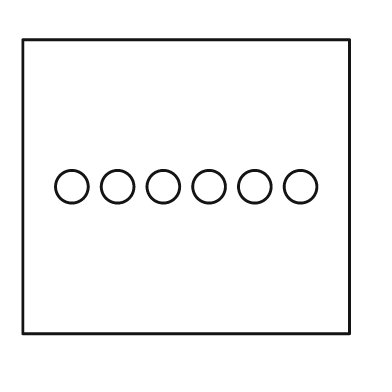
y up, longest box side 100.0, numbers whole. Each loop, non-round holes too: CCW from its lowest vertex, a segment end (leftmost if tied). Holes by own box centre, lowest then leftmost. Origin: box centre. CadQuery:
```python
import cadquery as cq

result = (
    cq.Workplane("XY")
    .moveTo(-50.0, -45.0)
    .lineTo(50.0, -45.0)
    .lineTo(50.0, 45.0)
    .lineTo(-50.0, 45.0)
    .close()
    .moveTo(-35.0, 0.0)
    .circle(5.0)
    .moveTo(-21.0, 0.0)
    .circle(5.0)
    .moveTo(-7.0, 0.0)
    .circle(5.0)
    .moveTo(7.0, 0.0)
    .circle(5.0)
    .moveTo(21.0, 0.0)
    .circle(5.0)
    .moveTo(35.0, 0.0)
    .circle(5.0)
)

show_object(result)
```